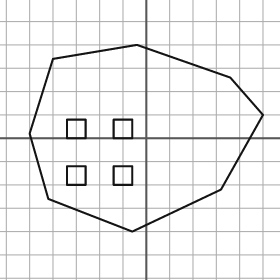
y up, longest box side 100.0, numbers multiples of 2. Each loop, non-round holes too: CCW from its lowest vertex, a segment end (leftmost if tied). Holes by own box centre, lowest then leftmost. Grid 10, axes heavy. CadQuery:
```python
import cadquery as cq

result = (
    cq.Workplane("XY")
    .moveTo(-6.0, -40.0)
    .lineTo(32.0, -22.0)
    .lineTo(50.0, 10.0)
    .lineTo(36.0, 26.0)
    .lineTo(-4.0, 40.0)
    .lineTo(-40.0, 34.0)
    .lineTo(-50.0, 2.0)
    .lineTo(-42.0, -26.0)
    .close()
    .moveTo(-34.0, -20.0)
    .lineTo(-26.0, -20.0)
    .lineTo(-26.0, -12.0)
    .lineTo(-34.0, -12.0)
    .close()
    .moveTo(-14.0, -20.0)
    .lineTo(-6.0, -20.0)
    .lineTo(-6.0, -12.0)
    .lineTo(-14.0, -12.0)
    .close()
    .moveTo(-34.0, 0.0)
    .lineTo(-26.0, 0.0)
    .lineTo(-26.0, 8.0)
    .lineTo(-34.0, 8.0)
    .close()
    .moveTo(-14.0, 0.0)
    .lineTo(-6.0, 0.0)
    .lineTo(-6.0, 8.0)
    .lineTo(-14.0, 8.0)
    .close()
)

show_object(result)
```